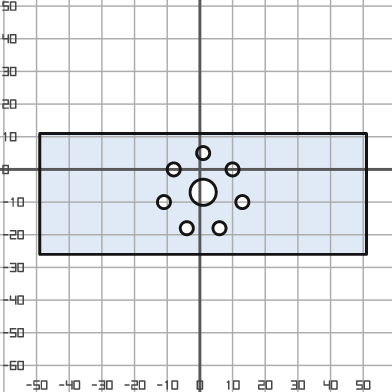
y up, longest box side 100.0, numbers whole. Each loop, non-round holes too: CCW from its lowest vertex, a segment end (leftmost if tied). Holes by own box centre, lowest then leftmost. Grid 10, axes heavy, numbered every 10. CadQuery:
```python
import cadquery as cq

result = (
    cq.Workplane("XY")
    .moveTo(-49.0, -26.0)
    .lineTo(51.0, -26.0)
    .lineTo(51.0, 11.0)
    .lineTo(-49.0, 11.0)
    .close()
    .moveTo(-4.0, -18.0)
    .circle(2.0)
    .moveTo(6.0, -18.0)
    .circle(2.0)
    .moveTo(-11.0, -10.0)
    .circle(2.0)
    .moveTo(13.0, -10.0)
    .circle(2.0)
    .moveTo(1.0, -7.0)
    .circle(4.0)
    .moveTo(-8.0, 0.0)
    .circle(2.0)
    .moveTo(10.0, 0.0)
    .circle(2.0)
    .moveTo(1.0, 5.0)
    .circle(2.0)
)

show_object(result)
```